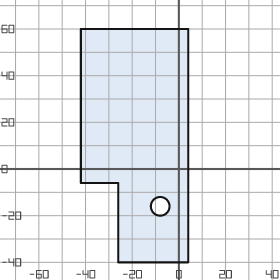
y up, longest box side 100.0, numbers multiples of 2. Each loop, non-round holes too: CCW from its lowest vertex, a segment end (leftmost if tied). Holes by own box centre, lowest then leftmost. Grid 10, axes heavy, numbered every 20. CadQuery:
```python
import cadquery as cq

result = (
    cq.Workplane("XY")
    .moveTo(-26.0, -40.0)
    .lineTo(4.0, -40.0)
    .lineTo(4.0, 60.0)
    .lineTo(-42.0, 60.0)
    .lineTo(-42.0, -6.0)
    .lineTo(-26.0, -6.0)
    .close()
    .moveTo(-8.0, -16.0)
    .circle(4.0)
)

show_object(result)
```